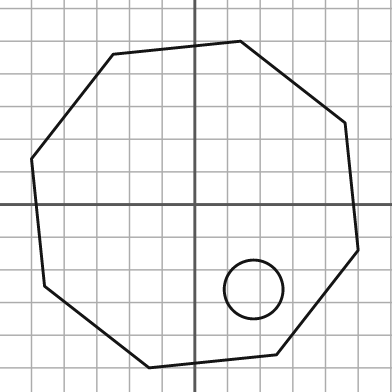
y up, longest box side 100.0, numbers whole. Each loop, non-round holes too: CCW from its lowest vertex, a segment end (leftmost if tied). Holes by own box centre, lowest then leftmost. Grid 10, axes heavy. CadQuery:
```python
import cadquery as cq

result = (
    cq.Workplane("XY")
    .moveTo(-14.0, -50.0)
    .lineTo(25.0, -46.0)
    .lineTo(50.0, -14.0)
    .lineTo(46.0, 25.0)
    .lineTo(14.0, 50.0)
    .lineTo(-25.0, 46.0)
    .lineTo(-50.0, 14.0)
    .lineTo(-46.0, -25.0)
    .close()
    .moveTo(18.0, -26.0)
    .circle(9.0)
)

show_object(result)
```